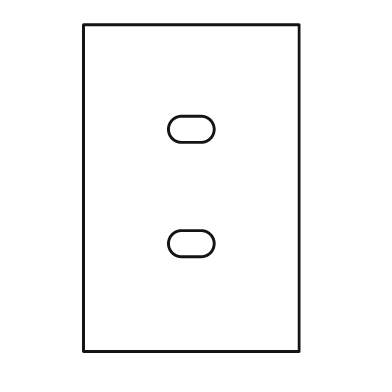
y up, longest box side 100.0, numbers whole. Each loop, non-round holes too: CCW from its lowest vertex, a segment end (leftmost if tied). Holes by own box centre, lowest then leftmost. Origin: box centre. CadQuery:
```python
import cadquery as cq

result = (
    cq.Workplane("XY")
    .moveTo(-33.0, -50.0)
    .lineTo(33.0, -50.0)
    .lineTo(33.0, 50.0)
    .lineTo(-33.0, 50.0)
    .close()
    .moveTo(-3.0, -21.0)
    .lineTo(3.0, -21.0)
    .threePointArc((7.0, -17.0), (3.0, -13.0))
    .lineTo(-3.0, -13.0)
    .threePointArc((-7.0, -17.0), (-3.0, -21.0))
    .close()
    .moveTo(-3.0, 14.0)
    .lineTo(3.0, 14.0)
    .threePointArc((7.0, 18.0), (3.0, 22.0))
    .lineTo(-3.0, 22.0)
    .threePointArc((-7.0, 18.0), (-3.0, 14.0))
    .close()
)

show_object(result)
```